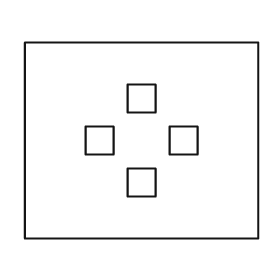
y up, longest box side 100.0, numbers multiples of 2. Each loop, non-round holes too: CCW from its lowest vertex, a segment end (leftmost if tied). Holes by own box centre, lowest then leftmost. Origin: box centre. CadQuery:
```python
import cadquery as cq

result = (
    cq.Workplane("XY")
    .moveTo(-50.0, -42.0)
    .lineTo(50.0, -42.0)
    .lineTo(50.0, 42.0)
    .lineTo(-50.0, 42.0)
    .close()
    .moveTo(-6.0, -24.0)
    .lineTo(6.0, -24.0)
    .lineTo(6.0, -12.0)
    .lineTo(-6.0, -12.0)
    .close()
    .moveTo(-24.0, -6.0)
    .lineTo(-12.0, -6.0)
    .lineTo(-12.0, 6.0)
    .lineTo(-24.0, 6.0)
    .close()
    .moveTo(12.0, -6.0)
    .lineTo(24.0, -6.0)
    .lineTo(24.0, 6.0)
    .lineTo(12.0, 6.0)
    .close()
    .moveTo(-6.0, 12.0)
    .lineTo(6.0, 12.0)
    .lineTo(6.0, 24.0)
    .lineTo(-6.0, 24.0)
    .close()
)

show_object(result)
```